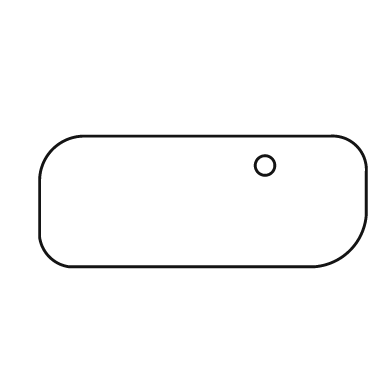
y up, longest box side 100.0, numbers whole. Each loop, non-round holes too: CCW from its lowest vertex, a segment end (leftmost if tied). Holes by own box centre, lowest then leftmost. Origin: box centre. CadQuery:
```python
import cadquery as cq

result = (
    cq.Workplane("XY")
    .moveTo(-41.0, -20.0)
    .lineTo(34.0, -20.0)
    .threePointArc((45.0, -15.0), (50.0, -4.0))
    .lineTo(50.0, 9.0)
    .threePointArc((47.0, 17.0), (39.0, 20.0))
    .lineTo(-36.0, 20.0)
    .threePointArc((-46.0, 16.0), (-50.0, 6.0))
    .lineTo(-50.0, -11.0)
    .threePointArc((-47.0, -17.0), (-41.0, -20.0))
    .close()
    .moveTo(19.0, 11.0)
    .circle(3.0)
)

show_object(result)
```